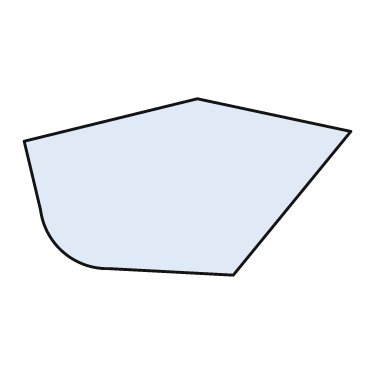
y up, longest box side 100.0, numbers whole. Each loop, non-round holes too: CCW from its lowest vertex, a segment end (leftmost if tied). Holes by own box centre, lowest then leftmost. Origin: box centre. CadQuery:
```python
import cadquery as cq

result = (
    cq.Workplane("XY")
    .moveTo(14.0, -27.0)
    .lineTo(50.0, 17.0)
    .lineTo(3.0, 27.0)
    .lineTo(-50.0, 14.0)
    .lineTo(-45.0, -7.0)
    .threePointArc((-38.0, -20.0), (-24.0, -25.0))
    .close()
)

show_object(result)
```